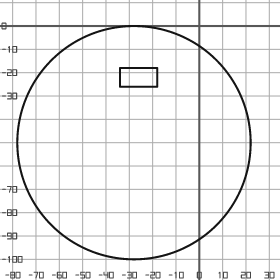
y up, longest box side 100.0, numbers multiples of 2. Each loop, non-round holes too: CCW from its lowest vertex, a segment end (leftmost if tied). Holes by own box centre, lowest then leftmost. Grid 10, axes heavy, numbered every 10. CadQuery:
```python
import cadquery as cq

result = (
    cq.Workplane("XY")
    .moveTo(-28.0, -50.0)
    .circle(50.0)
    .moveTo(-34.0, -26.0)
    .lineTo(-18.0, -26.0)
    .lineTo(-18.0, -18.0)
    .lineTo(-34.0, -18.0)
    .close()
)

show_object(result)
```